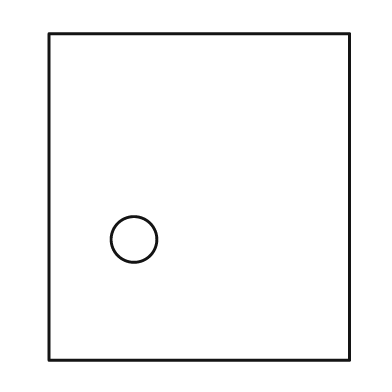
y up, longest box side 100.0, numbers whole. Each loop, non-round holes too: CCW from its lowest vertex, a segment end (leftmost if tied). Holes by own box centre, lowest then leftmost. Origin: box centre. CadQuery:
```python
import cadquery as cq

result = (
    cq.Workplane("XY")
    .moveTo(-46.0, -50.0)
    .lineTo(46.0, -50.0)
    .lineTo(46.0, 50.0)
    .lineTo(-46.0, 50.0)
    .close()
    .moveTo(-20.0, -13.0)
    .circle(7.0)
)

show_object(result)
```